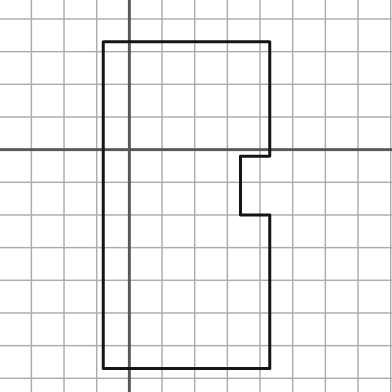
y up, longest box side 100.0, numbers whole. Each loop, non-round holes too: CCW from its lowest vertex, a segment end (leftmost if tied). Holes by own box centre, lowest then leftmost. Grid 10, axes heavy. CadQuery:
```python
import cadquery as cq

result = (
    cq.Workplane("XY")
    .moveTo(-8.0, -67.0)
    .lineTo(43.0, -67.0)
    .lineTo(43.0, -20.0)
    .lineTo(34.0, -20.0)
    .lineTo(34.0, -2.0)
    .lineTo(43.0, -2.0)
    .lineTo(43.0, 33.0)
    .lineTo(-8.0, 33.0)
    .close()
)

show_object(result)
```